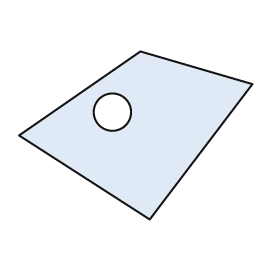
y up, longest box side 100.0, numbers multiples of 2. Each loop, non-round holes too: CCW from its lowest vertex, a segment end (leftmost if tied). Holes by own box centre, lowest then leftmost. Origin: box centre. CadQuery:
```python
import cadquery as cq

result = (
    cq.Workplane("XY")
    .moveTo(6.0, -36.0)
    .lineTo(50.0, 22.0)
    .lineTo(2.0, 36.0)
    .lineTo(-50.0, 0.0)
    .close()
    .moveTo(-10.0, 10.0)
    .circle(8.0)
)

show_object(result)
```